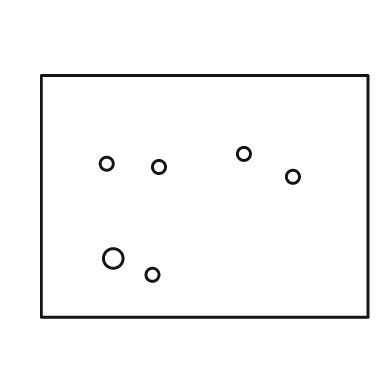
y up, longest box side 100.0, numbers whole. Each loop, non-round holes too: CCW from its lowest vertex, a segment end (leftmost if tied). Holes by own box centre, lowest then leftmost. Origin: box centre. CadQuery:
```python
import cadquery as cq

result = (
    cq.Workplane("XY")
    .moveTo(-50.0, -37.0)
    .lineTo(50.0, -37.0)
    .lineTo(50.0, 37.0)
    .lineTo(-50.0, 37.0)
    .close()
    .moveTo(-16.0, -24.0)
    .circle(2.0)
    .moveTo(-28.0, -19.0)
    .circle(3.0)
    .moveTo(27.0, 6.0)
    .circle(2.0)
    .moveTo(-14.0, 9.0)
    .circle(2.0)
    .moveTo(-30.0, 10.0)
    .circle(2.0)
    .moveTo(12.0, 13.0)
    .circle(2.0)
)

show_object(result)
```